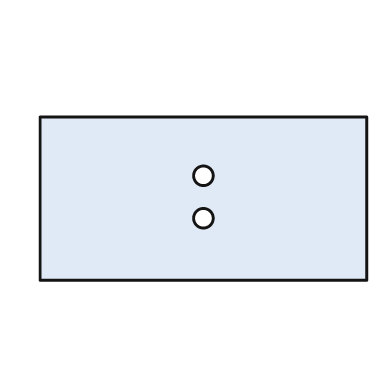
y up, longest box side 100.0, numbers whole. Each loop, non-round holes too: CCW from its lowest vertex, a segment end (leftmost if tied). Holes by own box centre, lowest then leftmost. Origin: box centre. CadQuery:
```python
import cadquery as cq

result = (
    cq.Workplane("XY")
    .moveTo(-50.0, -25.0)
    .lineTo(50.0, -25.0)
    .lineTo(50.0, 25.0)
    .lineTo(-50.0, 25.0)
    .close()
    .moveTo(0.0, -6.0)
    .circle(3.0)
    .moveTo(0.0, 7.0)
    .circle(3.0)
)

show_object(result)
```